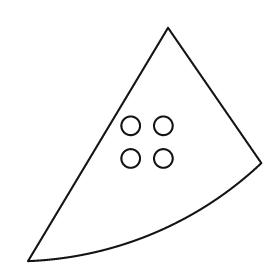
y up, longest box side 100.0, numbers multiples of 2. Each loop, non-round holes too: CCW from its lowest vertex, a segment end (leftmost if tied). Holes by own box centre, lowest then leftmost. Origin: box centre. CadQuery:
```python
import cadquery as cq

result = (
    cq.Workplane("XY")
    .moveTo(-50.0, -50.0)
    .threePointArc((4.0, -38.0), (50.0, -8.0))
    .lineTo(10.0, 50.0)
    .close()
    .moveTo(-6.0, -6.0)
    .circle(4.0)
    .moveTo(8.0, -6.0)
    .circle(4.0)
    .moveTo(-6.0, 8.0)
    .circle(4.0)
    .moveTo(8.0, 8.0)
    .circle(4.0)
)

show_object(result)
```